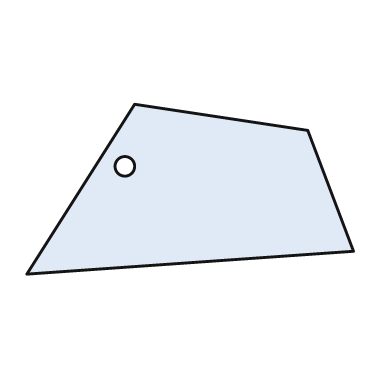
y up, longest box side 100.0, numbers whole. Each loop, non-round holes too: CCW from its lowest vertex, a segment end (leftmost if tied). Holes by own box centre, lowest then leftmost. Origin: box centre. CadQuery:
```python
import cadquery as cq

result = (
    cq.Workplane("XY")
    .moveTo(-50.0, -26.0)
    .lineTo(50.0, -19.0)
    .lineTo(36.0, 18.0)
    .lineTo(-17.0, 26.0)
    .close()
    .moveTo(-20.0, 7.0)
    .circle(3.0)
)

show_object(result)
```